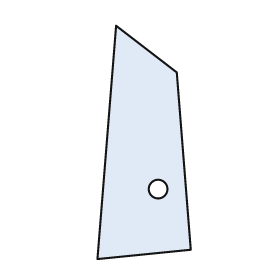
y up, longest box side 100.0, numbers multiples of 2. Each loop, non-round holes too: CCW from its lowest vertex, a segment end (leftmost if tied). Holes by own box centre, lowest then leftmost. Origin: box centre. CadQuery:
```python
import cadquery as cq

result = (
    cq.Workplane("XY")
    .moveTo(-20.0, -50.0)
    .lineTo(20.0, -46.0)
    .lineTo(14.0, 30.0)
    .lineTo(-12.0, 50.0)
    .close()
    .moveTo(6.0, -20.0)
    .circle(4.0)
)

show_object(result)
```